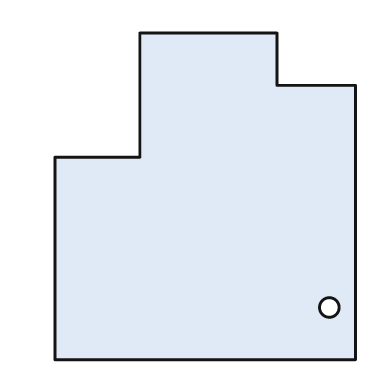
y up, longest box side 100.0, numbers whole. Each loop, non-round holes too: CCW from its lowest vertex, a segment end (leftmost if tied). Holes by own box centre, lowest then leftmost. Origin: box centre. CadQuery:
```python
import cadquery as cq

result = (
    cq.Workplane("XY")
    .moveTo(-46.0, -50.0)
    .lineTo(46.0, -50.0)
    .lineTo(46.0, 34.0)
    .lineTo(22.0, 34.0)
    .lineTo(22.0, 50.0)
    .lineTo(-20.0, 50.0)
    .lineTo(-20.0, 12.0)
    .lineTo(-46.0, 12.0)
    .close()
    .moveTo(38.0, -34.0)
    .circle(3.0)
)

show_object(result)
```